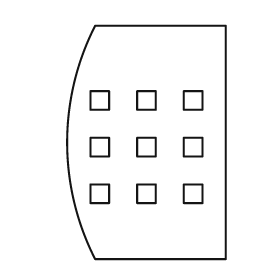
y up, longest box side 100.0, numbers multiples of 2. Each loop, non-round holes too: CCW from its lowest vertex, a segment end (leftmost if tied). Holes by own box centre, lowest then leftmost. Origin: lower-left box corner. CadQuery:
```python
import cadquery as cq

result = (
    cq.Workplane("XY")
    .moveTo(12.0, 0.0)
    .lineTo(68.0, 0.0)
    .lineTo(68.0, 100.0)
    .lineTo(12.0, 100.0)
    .threePointArc((0.0, 50.0), (12.0, 0.0))
    .close()
    .moveTo(10.0, 24.0)
    .lineTo(18.0, 24.0)
    .lineTo(18.0, 32.0)
    .lineTo(10.0, 32.0)
    .close()
    .moveTo(30.0, 24.0)
    .lineTo(38.0, 24.0)
    .lineTo(38.0, 32.0)
    .lineTo(30.0, 32.0)
    .close()
    .moveTo(50.0, 24.0)
    .lineTo(58.0, 24.0)
    .lineTo(58.0, 32.0)
    .lineTo(50.0, 32.0)
    .close()
    .moveTo(10.0, 44.0)
    .lineTo(18.0, 44.0)
    .lineTo(18.0, 52.0)
    .lineTo(10.0, 52.0)
    .close()
    .moveTo(30.0, 44.0)
    .lineTo(38.0, 44.0)
    .lineTo(38.0, 52.0)
    .lineTo(30.0, 52.0)
    .close()
    .moveTo(50.0, 44.0)
    .lineTo(58.0, 44.0)
    .lineTo(58.0, 52.0)
    .lineTo(50.0, 52.0)
    .close()
    .moveTo(10.0, 64.0)
    .lineTo(18.0, 64.0)
    .lineTo(18.0, 72.0)
    .lineTo(10.0, 72.0)
    .close()
    .moveTo(30.0, 64.0)
    .lineTo(38.0, 64.0)
    .lineTo(38.0, 72.0)
    .lineTo(30.0, 72.0)
    .close()
    .moveTo(50.0, 64.0)
    .lineTo(58.0, 64.0)
    .lineTo(58.0, 72.0)
    .lineTo(50.0, 72.0)
    .close()
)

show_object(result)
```